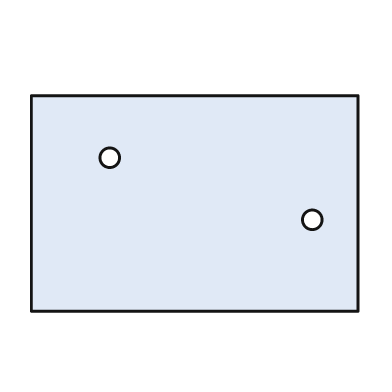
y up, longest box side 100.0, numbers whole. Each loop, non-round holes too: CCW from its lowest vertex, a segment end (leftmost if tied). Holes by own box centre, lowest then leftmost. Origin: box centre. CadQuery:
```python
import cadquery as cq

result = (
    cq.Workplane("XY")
    .moveTo(-50.0, -33.0)
    .lineTo(50.0, -33.0)
    .lineTo(50.0, 33.0)
    .lineTo(-50.0, 33.0)
    .close()
    .moveTo(36.0, -5.0)
    .circle(3.0)
    .moveTo(-26.0, 14.0)
    .circle(3.0)
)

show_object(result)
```